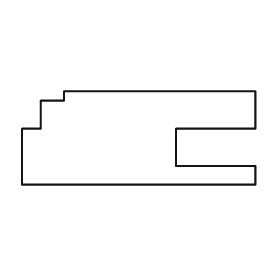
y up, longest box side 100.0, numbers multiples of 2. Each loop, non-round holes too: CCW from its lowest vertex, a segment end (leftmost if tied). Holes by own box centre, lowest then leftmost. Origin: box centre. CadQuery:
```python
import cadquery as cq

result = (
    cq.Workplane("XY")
    .moveTo(-50.0, -20.0)
    .lineTo(50.0, -20.0)
    .lineTo(50.0, -12.0)
    .lineTo(16.0, -12.0)
    .lineTo(16.0, 4.0)
    .lineTo(50.0, 4.0)
    .lineTo(50.0, 20.0)
    .lineTo(-32.0, 20.0)
    .lineTo(-32.0, 16.0)
    .lineTo(-42.0, 16.0)
    .lineTo(-42.0, 4.0)
    .lineTo(-50.0, 4.0)
    .close()
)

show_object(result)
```